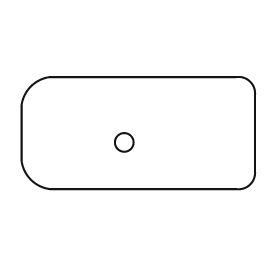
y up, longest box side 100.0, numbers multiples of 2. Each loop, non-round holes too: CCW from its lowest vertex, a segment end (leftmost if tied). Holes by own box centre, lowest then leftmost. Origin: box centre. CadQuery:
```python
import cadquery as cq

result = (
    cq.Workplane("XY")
    .moveTo(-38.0, -24.0)
    .lineTo(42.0, -24.0)
    .threePointArc((48.0, -22.0), (50.0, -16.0))
    .lineTo(50.0, 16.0)
    .threePointArc((48.0, 22.0), (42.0, 24.0))
    .lineTo(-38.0, 24.0)
    .threePointArc((-46.0, 20.0), (-50.0, 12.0))
    .lineTo(-50.0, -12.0)
    .threePointArc((-46.0, -20.0), (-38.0, -24.0))
    .close()
    .moveTo(-6.0, -4.0)
    .circle(4.0)
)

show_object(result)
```